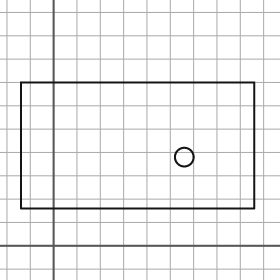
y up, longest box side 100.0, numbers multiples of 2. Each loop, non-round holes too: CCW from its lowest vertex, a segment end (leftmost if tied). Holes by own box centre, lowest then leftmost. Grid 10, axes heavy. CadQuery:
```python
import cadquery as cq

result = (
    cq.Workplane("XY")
    .moveTo(-14.0, 16.0)
    .lineTo(86.0, 16.0)
    .lineTo(86.0, 70.0)
    .lineTo(-14.0, 70.0)
    .close()
    .moveTo(56.0, 38.0)
    .circle(4.0)
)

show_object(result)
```